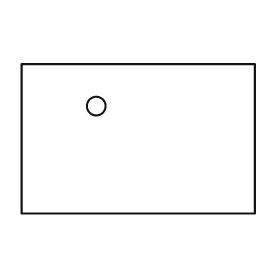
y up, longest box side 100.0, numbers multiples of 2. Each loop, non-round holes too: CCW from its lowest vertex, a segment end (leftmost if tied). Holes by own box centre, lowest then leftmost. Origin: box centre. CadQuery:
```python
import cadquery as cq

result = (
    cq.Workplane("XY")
    .moveTo(-50.0, -32.0)
    .lineTo(50.0, -32.0)
    .lineTo(50.0, 32.0)
    .lineTo(-50.0, 32.0)
    .close()
    .moveTo(-18.0, 14.0)
    .circle(4.0)
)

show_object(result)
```